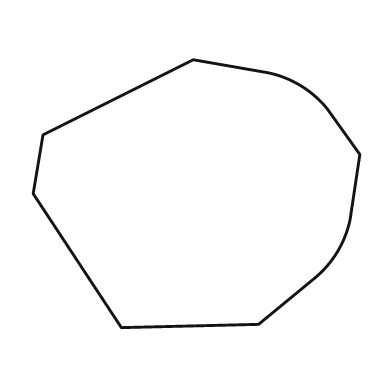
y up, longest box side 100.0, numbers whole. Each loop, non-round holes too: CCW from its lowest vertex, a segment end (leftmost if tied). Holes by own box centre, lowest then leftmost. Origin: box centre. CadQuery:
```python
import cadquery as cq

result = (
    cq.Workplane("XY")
    .moveTo(-23.0, -41.0)
    .lineTo(19.0, -40.0)
    .lineTo(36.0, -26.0)
    .threePointArc((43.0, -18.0), (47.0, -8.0))
    .lineTo(50.0, 12.0)
    .lineTo(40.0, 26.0)
    .threePointArc((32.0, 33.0), (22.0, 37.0))
    .lineTo(-1.0, 41.0)
    .lineTo(-47.0, 18.0)
    .lineTo(-50.0, 0.0)
    .close()
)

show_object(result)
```